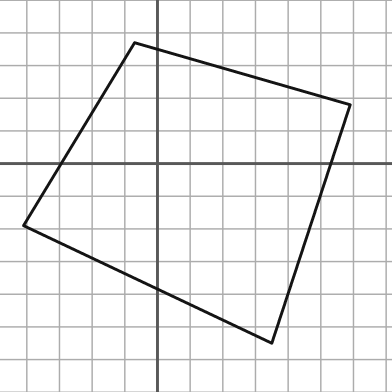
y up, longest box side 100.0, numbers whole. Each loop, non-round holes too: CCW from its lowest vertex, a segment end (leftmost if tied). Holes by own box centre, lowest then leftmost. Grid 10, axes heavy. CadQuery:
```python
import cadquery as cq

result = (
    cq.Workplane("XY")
    .moveTo(35.0, -55.0)
    .lineTo(59.0, 18.0)
    .lineTo(-7.0, 37.0)
    .lineTo(-41.0, -19.0)
    .close()
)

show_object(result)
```